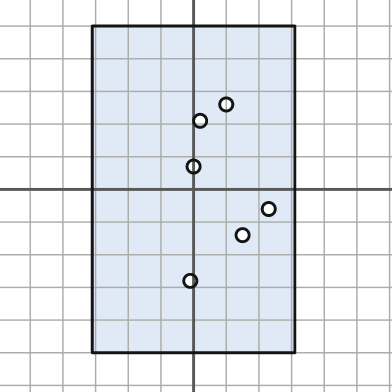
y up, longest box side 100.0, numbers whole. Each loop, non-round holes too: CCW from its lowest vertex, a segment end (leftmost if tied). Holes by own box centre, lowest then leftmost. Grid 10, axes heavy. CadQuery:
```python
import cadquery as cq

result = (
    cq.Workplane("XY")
    .moveTo(-31.0, -50.0)
    .lineTo(31.0, -50.0)
    .lineTo(31.0, 50.0)
    .lineTo(-31.0, 50.0)
    .close()
    .moveTo(-1.0, -28.0)
    .circle(2.0)
    .moveTo(15.0, -14.0)
    .circle(2.0)
    .moveTo(23.0, -6.0)
    .circle(2.0)
    .moveTo(0.0, 7.0)
    .circle(2.0)
    .moveTo(2.0, 21.0)
    .circle(2.0)
    .moveTo(10.0, 26.0)
    .circle(2.0)
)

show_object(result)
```